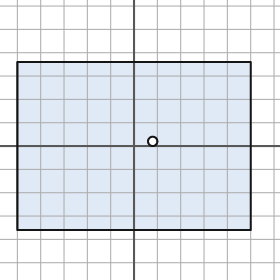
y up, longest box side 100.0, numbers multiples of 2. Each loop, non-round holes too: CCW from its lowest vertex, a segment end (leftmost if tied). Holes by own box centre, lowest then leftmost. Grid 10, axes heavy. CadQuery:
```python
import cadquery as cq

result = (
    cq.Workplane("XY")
    .moveTo(-50.0, -36.0)
    .lineTo(50.0, -36.0)
    .lineTo(50.0, 36.0)
    .lineTo(-50.0, 36.0)
    .close()
    .moveTo(8.0, 2.0)
    .circle(2.0)
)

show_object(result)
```